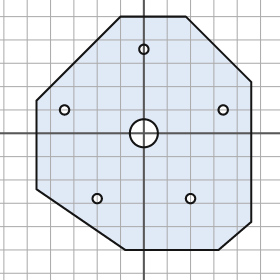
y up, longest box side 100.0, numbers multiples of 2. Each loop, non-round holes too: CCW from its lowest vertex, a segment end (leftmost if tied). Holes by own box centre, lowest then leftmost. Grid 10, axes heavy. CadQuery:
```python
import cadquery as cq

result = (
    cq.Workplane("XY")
    .moveTo(-8.0, -50.0)
    .lineTo(32.0, -50.0)
    .lineTo(46.0, -38.0)
    .lineTo(46.0, 22.0)
    .lineTo(18.0, 50.0)
    .lineTo(-10.0, 50.0)
    .lineTo(-46.0, 14.0)
    .lineTo(-46.0, -24.0)
    .close()
    .moveTo(-20.0, -28.0)
    .circle(2.0)
    .moveTo(20.0, -28.0)
    .circle(2.0)
    .moveTo(0.0, 0.0)
    .circle(6.0)
    .moveTo(-34.0, 10.0)
    .circle(2.0)
    .moveTo(34.0, 10.0)
    .circle(2.0)
    .moveTo(0.0, 36.0)
    .circle(2.0)
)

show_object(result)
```